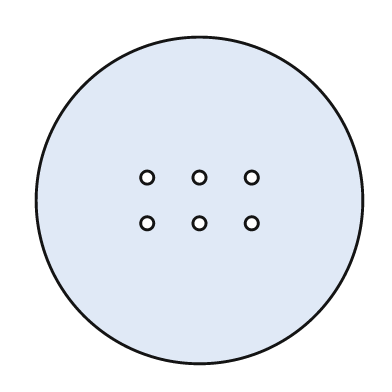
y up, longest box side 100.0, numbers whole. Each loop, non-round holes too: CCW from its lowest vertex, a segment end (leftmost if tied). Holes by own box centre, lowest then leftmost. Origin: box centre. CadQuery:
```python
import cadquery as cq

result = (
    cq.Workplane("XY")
    .moveTo(0.0, 0.0)
    .circle(50.0)
    .moveTo(-16.0, -7.0)
    .circle(2.0)
    .moveTo(0.0, -7.0)
    .circle(2.0)
    .moveTo(16.0, -7.0)
    .circle(2.0)
    .moveTo(-16.0, 7.0)
    .circle(2.0)
    .moveTo(0.0, 7.0)
    .circle(2.0)
    .moveTo(16.0, 7.0)
    .circle(2.0)
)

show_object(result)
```